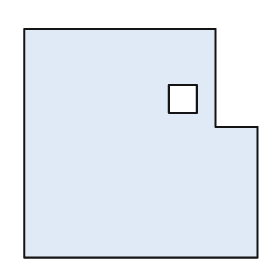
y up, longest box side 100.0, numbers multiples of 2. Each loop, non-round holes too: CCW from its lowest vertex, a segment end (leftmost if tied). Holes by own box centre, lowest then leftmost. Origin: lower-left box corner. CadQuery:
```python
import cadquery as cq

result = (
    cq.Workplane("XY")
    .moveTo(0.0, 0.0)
    .lineTo(100.0, 0.0)
    .lineTo(100.0, 56.0)
    .lineTo(82.0, 56.0)
    .lineTo(82.0, 98.0)
    .lineTo(0.0, 98.0)
    .close()
    .moveTo(62.0, 62.0)
    .lineTo(74.0, 62.0)
    .lineTo(74.0, 74.0)
    .lineTo(62.0, 74.0)
    .close()
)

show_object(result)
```